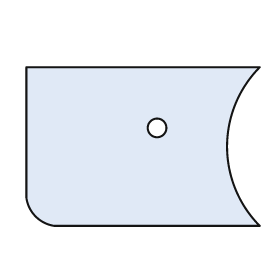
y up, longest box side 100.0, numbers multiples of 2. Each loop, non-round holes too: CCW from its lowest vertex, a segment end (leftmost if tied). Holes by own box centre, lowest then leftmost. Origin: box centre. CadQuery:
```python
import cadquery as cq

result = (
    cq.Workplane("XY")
    .moveTo(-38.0, -34.0)
    .lineTo(50.0, -34.0)
    .threePointArc((36.0, 0.0), (50.0, 34.0))
    .lineTo(-50.0, 34.0)
    .lineTo(-50.0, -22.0)
    .threePointArc((-46.0, -30.0), (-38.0, -34.0))
    .close()
    .moveTo(6.0, 8.0)
    .circle(4.0)
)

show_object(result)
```